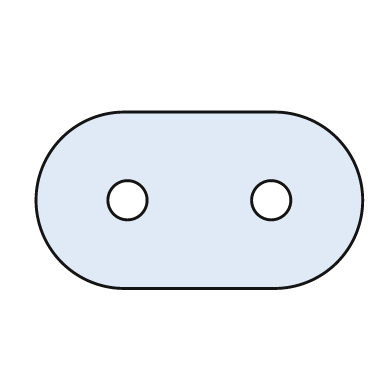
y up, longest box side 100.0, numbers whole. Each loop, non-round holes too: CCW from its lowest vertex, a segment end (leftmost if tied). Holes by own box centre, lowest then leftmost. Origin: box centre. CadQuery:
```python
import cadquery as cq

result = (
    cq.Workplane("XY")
    .moveTo(-23.0, -27.0)
    .lineTo(23.0, -27.0)
    .threePointArc((50.0, 0.0), (23.0, 27.0))
    .lineTo(-23.0, 27.0)
    .threePointArc((-50.0, 0.0), (-23.0, -27.0))
    .close()
    .moveTo(-22.0, 0.0)
    .circle(6.0)
    .moveTo(22.0, 0.0)
    .circle(6.0)
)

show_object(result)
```